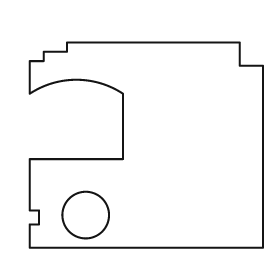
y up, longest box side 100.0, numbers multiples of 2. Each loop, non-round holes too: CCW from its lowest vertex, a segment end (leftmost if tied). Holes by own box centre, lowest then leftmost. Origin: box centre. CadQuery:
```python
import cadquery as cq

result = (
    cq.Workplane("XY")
    .moveTo(-50.0, -44.0)
    .lineTo(50.0, -44.0)
    .lineTo(50.0, 34.0)
    .lineTo(40.0, 34.0)
    .lineTo(40.0, 44.0)
    .lineTo(-34.0, 44.0)
    .lineTo(-34.0, 40.0)
    .lineTo(-44.0, 40.0)
    .lineTo(-44.0, 36.0)
    .lineTo(-50.0, 36.0)
    .lineTo(-50.0, 22.0)
    .threePointArc((-30.0, 28.0), (-10.0, 22.0))
    .lineTo(-10.0, -6.0)
    .lineTo(-50.0, -6.0)
    .lineTo(-50.0, -28.0)
    .lineTo(-46.0, -28.0)
    .lineTo(-46.0, -34.0)
    .lineTo(-50.0, -34.0)
    .close()
    .moveTo(-26.0, -30.0)
    .circle(10.0)
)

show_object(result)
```